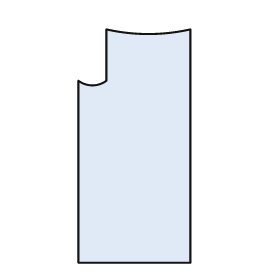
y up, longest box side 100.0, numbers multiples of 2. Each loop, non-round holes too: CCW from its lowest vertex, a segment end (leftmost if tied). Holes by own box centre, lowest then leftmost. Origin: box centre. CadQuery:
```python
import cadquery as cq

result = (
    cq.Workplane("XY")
    .moveTo(-24.0, -50.0)
    .lineTo(24.0, -50.0)
    .lineTo(24.0, 50.0)
    .threePointArc((6.0, 48.0), (-12.0, 50.0))
    .lineTo(-12.0, 28.0)
    .threePointArc((-18.0, 26.0), (-24.0, 28.0))
    .close()
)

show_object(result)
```